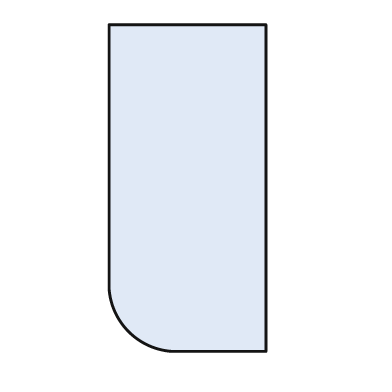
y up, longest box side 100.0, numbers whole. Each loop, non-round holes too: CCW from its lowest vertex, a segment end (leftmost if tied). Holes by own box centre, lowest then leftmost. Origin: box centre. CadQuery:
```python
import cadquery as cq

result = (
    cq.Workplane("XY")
    .moveTo(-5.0, -50.0)
    .lineTo(24.0, -50.0)
    .lineTo(24.0, 50.0)
    .lineTo(-24.0, 50.0)
    .lineTo(-24.0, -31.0)
    .threePointArc((-18.0, -44.0), (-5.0, -50.0))
    .close()
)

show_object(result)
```